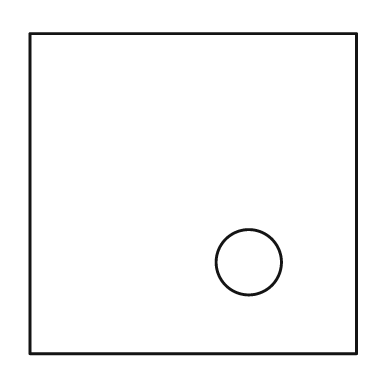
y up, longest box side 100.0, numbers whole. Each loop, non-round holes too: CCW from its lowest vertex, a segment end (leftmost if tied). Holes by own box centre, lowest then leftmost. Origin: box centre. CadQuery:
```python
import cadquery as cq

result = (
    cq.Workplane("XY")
    .moveTo(-50.0, -49.0)
    .lineTo(50.0, -49.0)
    .lineTo(50.0, 49.0)
    .lineTo(-50.0, 49.0)
    .close()
    .moveTo(17.0, -21.0)
    .circle(10.0)
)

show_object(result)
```